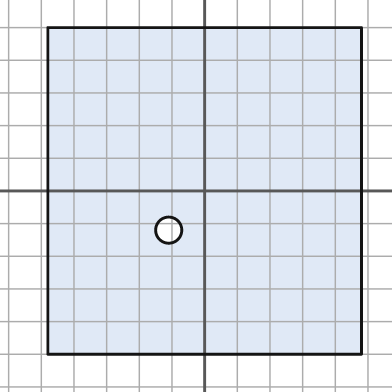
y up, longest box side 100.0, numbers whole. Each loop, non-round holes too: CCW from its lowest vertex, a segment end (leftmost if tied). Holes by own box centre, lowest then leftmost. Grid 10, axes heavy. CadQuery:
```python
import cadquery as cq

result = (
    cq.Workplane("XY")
    .moveTo(-48.0, -50.0)
    .lineTo(48.0, -50.0)
    .lineTo(48.0, 50.0)
    .lineTo(-48.0, 50.0)
    .close()
    .moveTo(-11.0, -12.0)
    .circle(4.0)
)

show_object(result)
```